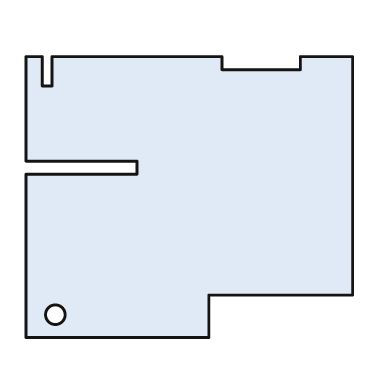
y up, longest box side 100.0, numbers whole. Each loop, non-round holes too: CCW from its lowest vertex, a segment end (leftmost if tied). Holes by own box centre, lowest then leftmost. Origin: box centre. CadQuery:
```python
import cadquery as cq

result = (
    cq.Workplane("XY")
    .moveTo(-50.0, -43.0)
    .lineTo(6.0, -43.0)
    .lineTo(6.0, -30.0)
    .lineTo(50.0, -30.0)
    .lineTo(50.0, 43.0)
    .lineTo(34.0, 43.0)
    .lineTo(34.0, 39.0)
    .lineTo(10.0, 39.0)
    .lineTo(10.0, 43.0)
    .lineTo(-42.0, 43.0)
    .lineTo(-42.0, 34.0)
    .lineTo(-45.0, 34.0)
    .lineTo(-45.0, 43.0)
    .lineTo(-50.0, 43.0)
    .lineTo(-50.0, 11.0)
    .lineTo(-16.0, 11.0)
    .lineTo(-16.0, 7.0)
    .lineTo(-50.0, 7.0)
    .close()
    .moveTo(-41.0, -36.0)
    .circle(3.0)
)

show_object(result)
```